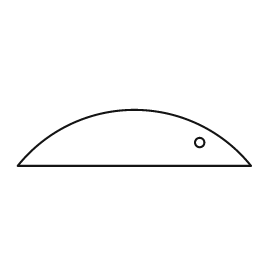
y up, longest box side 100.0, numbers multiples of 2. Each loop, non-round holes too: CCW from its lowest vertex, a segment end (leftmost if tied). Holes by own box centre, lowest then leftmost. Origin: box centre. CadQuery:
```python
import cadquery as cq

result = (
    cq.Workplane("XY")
    .moveTo(-50.0, -12.0)
    .lineTo(50.0, -12.0)
    .threePointArc((0.0, 12.0), (-50.0, -12.0))
    .close()
    .moveTo(28.0, -2.0)
    .circle(2.0)
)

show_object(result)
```